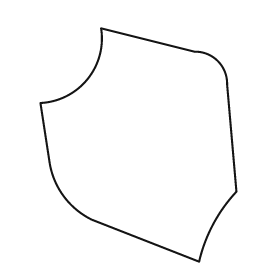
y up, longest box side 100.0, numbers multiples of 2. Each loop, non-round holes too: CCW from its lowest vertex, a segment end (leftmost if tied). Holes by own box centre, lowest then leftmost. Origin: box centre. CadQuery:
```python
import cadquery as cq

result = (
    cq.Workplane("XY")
    .moveTo(26.0, -50.0)
    .threePointArc((32.0, -34.0), (42.0, -20.0))
    .lineTo(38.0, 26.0)
    .threePointArc((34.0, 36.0), (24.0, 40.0))
    .lineTo(-16.0, 50.0)
    .threePointArc((-22.0, 28.0), (-42.0, 18.0))
    .lineTo(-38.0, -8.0)
    .threePointArc((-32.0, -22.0), (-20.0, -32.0))
    .close()
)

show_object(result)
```